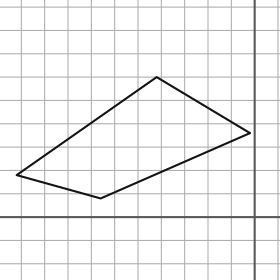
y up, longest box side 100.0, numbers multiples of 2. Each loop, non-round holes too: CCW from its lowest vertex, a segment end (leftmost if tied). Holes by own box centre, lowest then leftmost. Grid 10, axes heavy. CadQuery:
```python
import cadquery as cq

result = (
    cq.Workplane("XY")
    .moveTo(-66.0, 8.0)
    .lineTo(-2.0, 36.0)
    .lineTo(-42.0, 60.0)
    .lineTo(-102.0, 18.0)
    .close()
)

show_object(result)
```